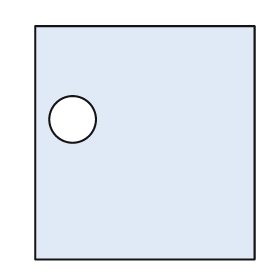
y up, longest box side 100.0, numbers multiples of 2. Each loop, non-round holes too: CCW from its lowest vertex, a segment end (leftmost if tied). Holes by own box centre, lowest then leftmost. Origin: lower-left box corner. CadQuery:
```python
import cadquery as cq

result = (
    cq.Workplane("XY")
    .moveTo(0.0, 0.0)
    .lineTo(94.0, 0.0)
    .lineTo(94.0, 100.0)
    .lineTo(0.0, 100.0)
    .close()
    .moveTo(16.0, 60.0)
    .circle(10.0)
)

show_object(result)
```